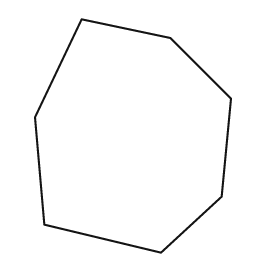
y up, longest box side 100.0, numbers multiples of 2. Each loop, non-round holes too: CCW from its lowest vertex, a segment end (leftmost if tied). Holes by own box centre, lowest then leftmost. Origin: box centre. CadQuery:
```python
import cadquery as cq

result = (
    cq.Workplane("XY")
    .moveTo(12.0, -50.0)
    .lineTo(38.0, -26.0)
    .lineTo(42.0, 16.0)
    .lineTo(16.0, 42.0)
    .lineTo(-22.0, 50.0)
    .lineTo(-42.0, 8.0)
    .lineTo(-38.0, -38.0)
    .close()
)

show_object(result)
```